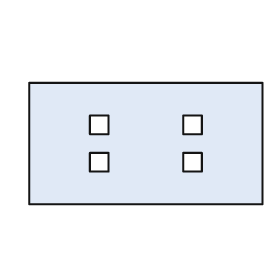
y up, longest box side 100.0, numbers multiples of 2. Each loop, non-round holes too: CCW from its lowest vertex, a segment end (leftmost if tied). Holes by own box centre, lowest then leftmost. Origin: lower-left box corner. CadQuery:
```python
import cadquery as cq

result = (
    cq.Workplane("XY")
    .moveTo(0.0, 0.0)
    .lineTo(100.0, 0.0)
    .lineTo(100.0, 52.0)
    .lineTo(0.0, 52.0)
    .close()
    .moveTo(26.0, 14.0)
    .lineTo(34.0, 14.0)
    .lineTo(34.0, 22.0)
    .lineTo(26.0, 22.0)
    .close()
    .moveTo(66.0, 14.0)
    .lineTo(74.0, 14.0)
    .lineTo(74.0, 22.0)
    .lineTo(66.0, 22.0)
    .close()
    .moveTo(26.0, 30.0)
    .lineTo(34.0, 30.0)
    .lineTo(34.0, 38.0)
    .lineTo(26.0, 38.0)
    .close()
    .moveTo(66.0, 30.0)
    .lineTo(74.0, 30.0)
    .lineTo(74.0, 38.0)
    .lineTo(66.0, 38.0)
    .close()
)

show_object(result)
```